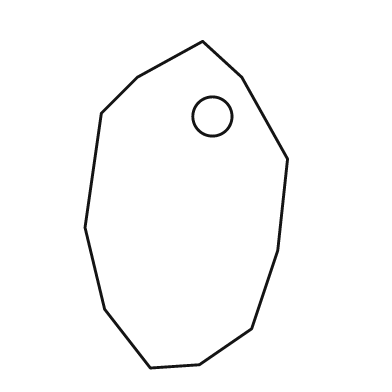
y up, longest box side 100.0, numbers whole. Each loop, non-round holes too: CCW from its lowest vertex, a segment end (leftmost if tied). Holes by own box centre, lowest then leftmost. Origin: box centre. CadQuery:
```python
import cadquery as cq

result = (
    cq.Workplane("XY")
    .moveTo(-11.0, -50.0)
    .lineTo(4.0, -49.0)
    .lineTo(20.0, -38.0)
    .lineTo(28.0, -14.0)
    .lineTo(31.0, 14.0)
    .lineTo(17.0, 39.0)
    .lineTo(5.0, 50.0)
    .lineTo(-15.0, 39.0)
    .lineTo(-26.0, 28.0)
    .lineTo(-31.0, -7.0)
    .lineTo(-25.0, -32.0)
    .close()
    .moveTo(8.0, 27.0)
    .circle(6.0)
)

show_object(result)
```